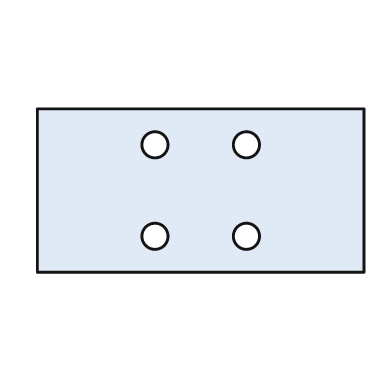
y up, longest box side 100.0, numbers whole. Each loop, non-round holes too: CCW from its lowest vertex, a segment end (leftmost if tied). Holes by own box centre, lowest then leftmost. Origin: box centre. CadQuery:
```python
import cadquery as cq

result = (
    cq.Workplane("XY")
    .moveTo(-50.0, -25.0)
    .lineTo(50.0, -25.0)
    .lineTo(50.0, 25.0)
    .lineTo(-50.0, 25.0)
    .close()
    .moveTo(-14.0, -14.0)
    .circle(4.0)
    .moveTo(14.0, -14.0)
    .circle(4.0)
    .moveTo(-14.0, 14.0)
    .circle(4.0)
    .moveTo(14.0, 14.0)
    .circle(4.0)
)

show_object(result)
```